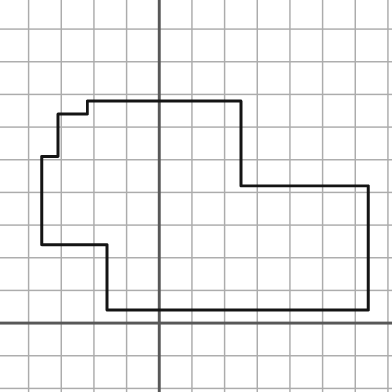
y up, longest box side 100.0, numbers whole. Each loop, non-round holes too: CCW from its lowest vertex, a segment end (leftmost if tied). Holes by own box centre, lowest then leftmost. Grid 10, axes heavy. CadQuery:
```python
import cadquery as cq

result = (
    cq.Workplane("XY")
    .moveTo(-16.0, 4.0)
    .lineTo(64.0, 4.0)
    .lineTo(64.0, 42.0)
    .lineTo(25.0, 42.0)
    .lineTo(25.0, 68.0)
    .lineTo(-22.0, 68.0)
    .lineTo(-22.0, 64.0)
    .lineTo(-31.0, 64.0)
    .lineTo(-31.0, 51.0)
    .lineTo(-36.0, 51.0)
    .lineTo(-36.0, 24.0)
    .lineTo(-16.0, 24.0)
    .close()
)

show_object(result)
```